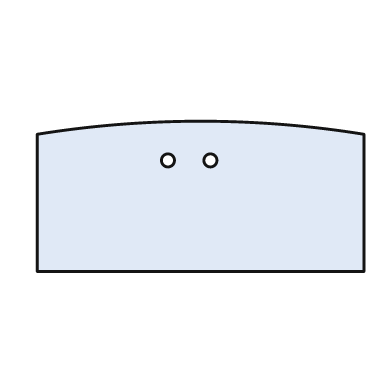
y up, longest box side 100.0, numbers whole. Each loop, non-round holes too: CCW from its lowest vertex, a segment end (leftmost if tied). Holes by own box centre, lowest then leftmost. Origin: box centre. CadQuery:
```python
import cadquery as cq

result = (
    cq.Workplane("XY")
    .moveTo(-50.0, -23.0)
    .lineTo(50.0, -23.0)
    .lineTo(50.0, 19.0)
    .threePointArc((0.0, 23.0), (-50.0, 19.0))
    .close()
    .moveTo(-10.0, 11.0)
    .circle(2.0)
    .moveTo(3.0, 11.0)
    .circle(2.0)
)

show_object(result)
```